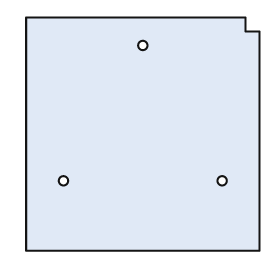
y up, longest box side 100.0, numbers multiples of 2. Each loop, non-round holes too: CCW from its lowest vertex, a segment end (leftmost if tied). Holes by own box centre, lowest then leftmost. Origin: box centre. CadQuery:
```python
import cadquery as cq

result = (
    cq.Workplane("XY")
    .moveTo(-50.0, -50.0)
    .lineTo(50.0, -50.0)
    .lineTo(50.0, 44.0)
    .lineTo(44.0, 44.0)
    .lineTo(44.0, 50.0)
    .lineTo(-50.0, 50.0)
    .close()
    .moveTo(-34.0, -20.0)
    .circle(2.0)
    .moveTo(34.0, -20.0)
    .circle(2.0)
    .moveTo(0.0, 38.0)
    .circle(2.0)
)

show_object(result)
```